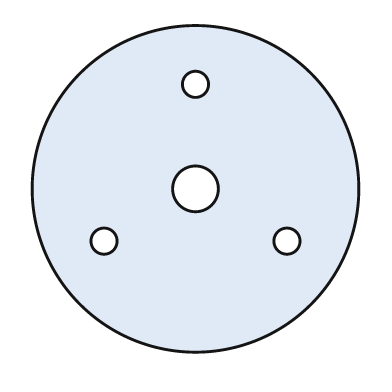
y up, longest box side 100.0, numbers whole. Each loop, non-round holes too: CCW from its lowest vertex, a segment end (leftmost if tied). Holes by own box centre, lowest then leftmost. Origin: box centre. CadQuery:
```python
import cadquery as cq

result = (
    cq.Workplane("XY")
    .moveTo(0.0, 0.0)
    .circle(50.0)
    .moveTo(-28.0, -16.0)
    .circle(4.0)
    .moveTo(28.0, -16.0)
    .circle(4.0)
    .moveTo(0.0, 0.0)
    .circle(7.0)
    .moveTo(0.0, 32.0)
    .circle(4.0)
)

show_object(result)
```